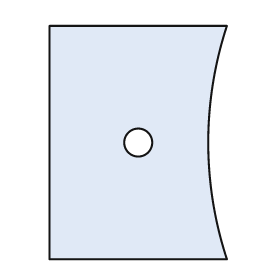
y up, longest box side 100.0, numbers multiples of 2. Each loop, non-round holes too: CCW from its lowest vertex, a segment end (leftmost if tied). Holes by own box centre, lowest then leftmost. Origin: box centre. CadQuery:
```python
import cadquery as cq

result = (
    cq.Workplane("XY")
    .moveTo(-38.0, -50.0)
    .lineTo(38.0, -50.0)
    .threePointArc((30.0, 0.0), (38.0, 50.0))
    .lineTo(-38.0, 50.0)
    .close()
    .moveTo(0.0, 0.0)
    .circle(6.0)
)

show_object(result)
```